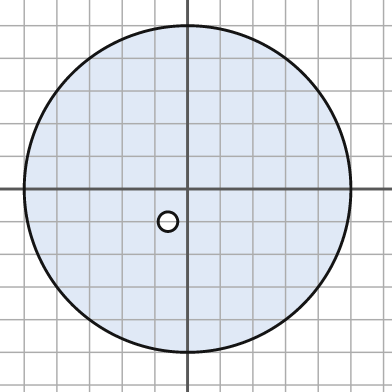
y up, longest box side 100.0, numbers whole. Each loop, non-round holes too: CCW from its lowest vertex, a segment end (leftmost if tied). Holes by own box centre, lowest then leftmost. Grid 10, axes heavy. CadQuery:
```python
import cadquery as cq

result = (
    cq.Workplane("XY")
    .moveTo(0.0, 0.0)
    .circle(50.0)
    .moveTo(-6.0, -10.0)
    .circle(3.0)
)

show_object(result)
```